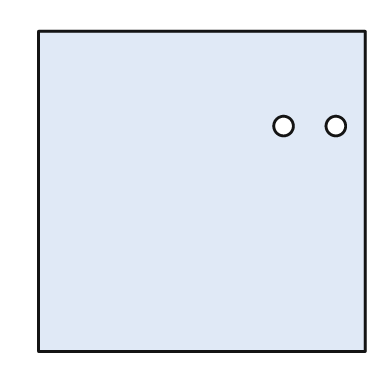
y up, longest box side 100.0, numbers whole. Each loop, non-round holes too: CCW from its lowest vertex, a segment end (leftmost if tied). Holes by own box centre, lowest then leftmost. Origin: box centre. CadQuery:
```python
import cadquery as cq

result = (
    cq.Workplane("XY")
    .moveTo(-50.0, -49.0)
    .lineTo(50.0, -49.0)
    .lineTo(50.0, 49.0)
    .lineTo(-50.0, 49.0)
    .close()
    .moveTo(25.0, 20.0)
    .circle(3.0)
    .moveTo(41.0, 20.0)
    .circle(3.0)
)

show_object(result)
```